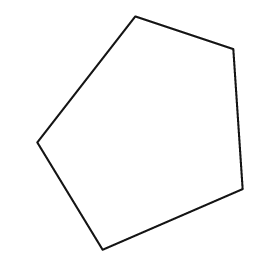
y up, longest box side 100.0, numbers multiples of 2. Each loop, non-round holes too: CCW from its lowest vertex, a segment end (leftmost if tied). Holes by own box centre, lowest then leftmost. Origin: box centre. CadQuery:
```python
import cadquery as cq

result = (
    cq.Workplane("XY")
    .moveTo(-16.0, -50.0)
    .lineTo(44.0, -24.0)
    .lineTo(40.0, 36.0)
    .lineTo(-2.0, 50.0)
    .lineTo(-44.0, -4.0)
    .close()
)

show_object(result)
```